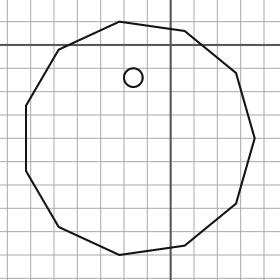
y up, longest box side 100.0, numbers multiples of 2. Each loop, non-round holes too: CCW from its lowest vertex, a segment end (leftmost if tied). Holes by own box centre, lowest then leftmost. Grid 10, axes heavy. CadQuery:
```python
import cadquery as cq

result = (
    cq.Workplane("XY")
    .moveTo(-22.0, -90.0)
    .lineTo(6.0, -86.0)
    .lineTo(28.0, -68.0)
    .lineTo(36.0, -40.0)
    .lineTo(28.0, -12.0)
    .lineTo(6.0, 6.0)
    .lineTo(-22.0, 10.0)
    .lineTo(-48.0, -2.0)
    .lineTo(-62.0, -26.0)
    .lineTo(-62.0, -54.0)
    .lineTo(-48.0, -78.0)
    .close()
    .moveTo(-16.0, -14.0)
    .circle(4.0)
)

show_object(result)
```